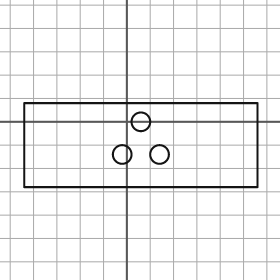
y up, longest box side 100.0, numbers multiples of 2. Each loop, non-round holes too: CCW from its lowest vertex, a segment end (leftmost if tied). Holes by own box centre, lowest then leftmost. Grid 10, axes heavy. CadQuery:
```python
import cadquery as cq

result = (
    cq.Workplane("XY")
    .moveTo(-44.0, -28.0)
    .lineTo(56.0, -28.0)
    .lineTo(56.0, 8.0)
    .lineTo(-44.0, 8.0)
    .close()
    .moveTo(-2.0, -14.0)
    .circle(4.0)
    .moveTo(14.0, -14.0)
    .circle(4.0)
    .moveTo(6.0, 0.0)
    .circle(4.0)
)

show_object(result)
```